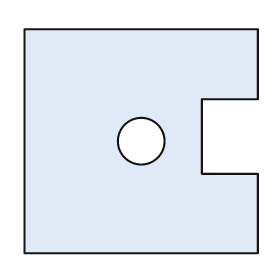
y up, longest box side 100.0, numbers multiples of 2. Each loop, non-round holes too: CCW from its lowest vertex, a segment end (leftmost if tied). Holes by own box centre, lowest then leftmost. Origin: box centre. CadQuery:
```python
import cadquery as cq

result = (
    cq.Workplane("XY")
    .moveTo(-50.0, -48.0)
    .lineTo(50.0, -48.0)
    .lineTo(50.0, -14.0)
    .lineTo(26.0, -14.0)
    .lineTo(26.0, 18.0)
    .lineTo(50.0, 18.0)
    .lineTo(50.0, 48.0)
    .lineTo(-50.0, 48.0)
    .close()
    .moveTo(0.0, 0.0)
    .circle(10.0)
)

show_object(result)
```